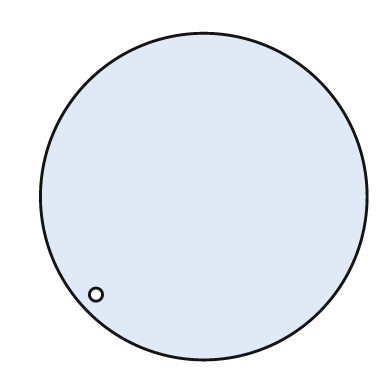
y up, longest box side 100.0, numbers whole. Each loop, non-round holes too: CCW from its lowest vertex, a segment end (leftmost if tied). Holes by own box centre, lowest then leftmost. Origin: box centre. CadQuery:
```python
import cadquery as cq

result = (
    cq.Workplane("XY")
    .moveTo(0.0, 0.0)
    .circle(50.0)
    .moveTo(-33.0, -30.0)
    .circle(2.0)
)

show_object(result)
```